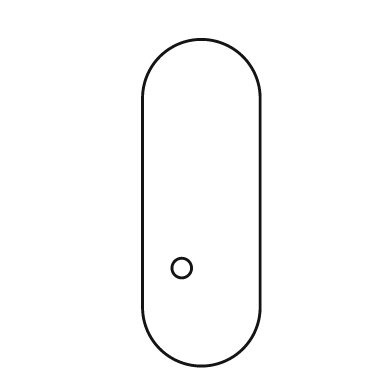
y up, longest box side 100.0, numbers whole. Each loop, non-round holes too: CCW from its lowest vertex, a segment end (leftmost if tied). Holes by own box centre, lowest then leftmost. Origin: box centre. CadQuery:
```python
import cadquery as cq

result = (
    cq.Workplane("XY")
    .moveTo(-18.0, -32.0)
    .threePointArc((0.0, -50.0), (18.0, -32.0))
    .lineTo(18.0, 32.0)
    .threePointArc((0.0, 50.0), (-18.0, 32.0))
    .close()
    .moveTo(-6.0, -20.0)
    .circle(3.0)
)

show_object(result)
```